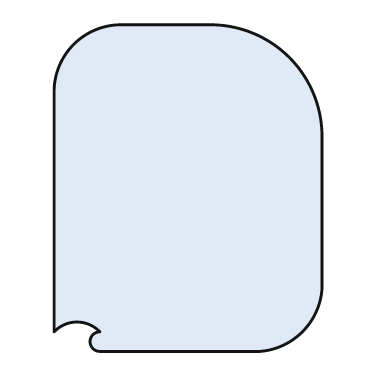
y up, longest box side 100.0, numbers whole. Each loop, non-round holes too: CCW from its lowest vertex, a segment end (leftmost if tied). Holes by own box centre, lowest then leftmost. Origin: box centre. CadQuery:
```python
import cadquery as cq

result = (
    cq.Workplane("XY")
    .moveTo(-27.0, -50.0)
    .lineTo(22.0, -50.0)
    .threePointArc((35.0, -44.0), (41.0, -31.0))
    .lineTo(41.0, 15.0)
    .threePointArc((31.0, 40.0), (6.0, 50.0))
    .lineTo(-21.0, 50.0)
    .threePointArc((-35.0, 44.0), (-41.0, 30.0))
    .lineTo(-41.0, -44.0)
    .threePointArc((-34.0, -41.0), (-27.0, -44.0))
    .threePointArc((-30.0, -47.0), (-27.0, -50.0))
    .close()
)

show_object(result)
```